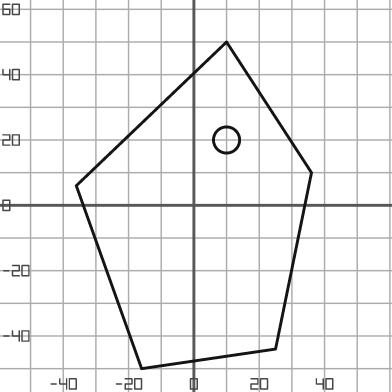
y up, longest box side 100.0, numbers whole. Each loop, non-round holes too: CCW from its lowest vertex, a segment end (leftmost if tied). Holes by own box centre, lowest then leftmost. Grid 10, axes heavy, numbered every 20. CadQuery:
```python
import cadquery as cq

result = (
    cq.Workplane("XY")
    .moveTo(-16.0, -50.0)
    .lineTo(25.0, -44.0)
    .lineTo(36.0, 10.0)
    .lineTo(10.0, 50.0)
    .lineTo(-36.0, 6.0)
    .close()
    .moveTo(10.0, 20.0)
    .circle(4.0)
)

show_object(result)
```